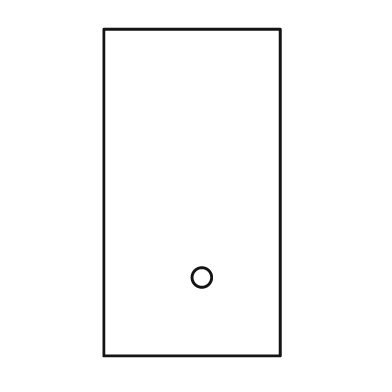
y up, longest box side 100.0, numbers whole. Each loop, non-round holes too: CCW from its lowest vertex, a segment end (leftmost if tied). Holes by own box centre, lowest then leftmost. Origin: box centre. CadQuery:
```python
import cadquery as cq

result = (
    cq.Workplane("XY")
    .moveTo(-27.0, -50.0)
    .lineTo(27.0, -50.0)
    .lineTo(27.0, 50.0)
    .lineTo(-27.0, 50.0)
    .close()
    .moveTo(3.0, -26.0)
    .circle(3.0)
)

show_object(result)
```